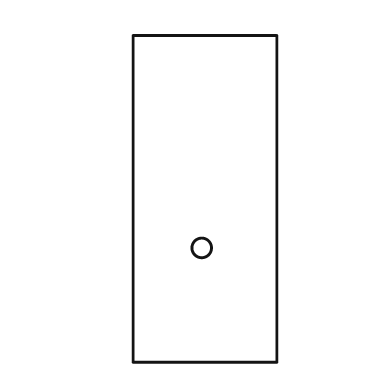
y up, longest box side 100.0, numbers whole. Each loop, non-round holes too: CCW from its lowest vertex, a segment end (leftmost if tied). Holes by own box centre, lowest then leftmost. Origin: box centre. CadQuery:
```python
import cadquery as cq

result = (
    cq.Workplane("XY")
    .moveTo(-22.0, -50.0)
    .lineTo(22.0, -50.0)
    .lineTo(22.0, 50.0)
    .lineTo(-22.0, 50.0)
    .close()
    .moveTo(-1.0, -15.0)
    .circle(3.0)
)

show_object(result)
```